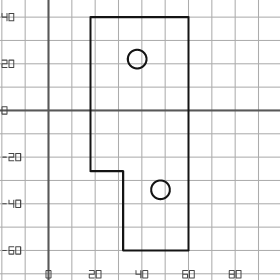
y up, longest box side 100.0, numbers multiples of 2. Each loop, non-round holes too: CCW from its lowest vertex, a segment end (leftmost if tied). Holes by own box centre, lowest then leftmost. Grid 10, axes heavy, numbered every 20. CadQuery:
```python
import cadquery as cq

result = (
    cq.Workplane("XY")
    .moveTo(32.0, -60.0)
    .lineTo(60.0, -60.0)
    .lineTo(60.0, 40.0)
    .lineTo(18.0, 40.0)
    .lineTo(18.0, -26.0)
    .lineTo(32.0, -26.0)
    .close()
    .moveTo(48.0, -34.0)
    .circle(4.0)
    .moveTo(38.0, 22.0)
    .circle(4.0)
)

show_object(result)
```